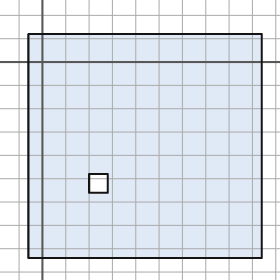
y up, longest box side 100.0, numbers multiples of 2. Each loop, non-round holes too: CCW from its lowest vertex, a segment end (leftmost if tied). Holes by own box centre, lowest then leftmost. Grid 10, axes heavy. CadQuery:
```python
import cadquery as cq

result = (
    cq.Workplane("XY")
    .moveTo(-6.0, -84.0)
    .lineTo(94.0, -84.0)
    .lineTo(94.0, 12.0)
    .lineTo(-6.0, 12.0)
    .close()
    .moveTo(20.0, -56.0)
    .lineTo(28.0, -56.0)
    .lineTo(28.0, -48.0)
    .lineTo(20.0, -48.0)
    .close()
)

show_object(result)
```